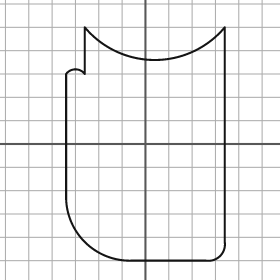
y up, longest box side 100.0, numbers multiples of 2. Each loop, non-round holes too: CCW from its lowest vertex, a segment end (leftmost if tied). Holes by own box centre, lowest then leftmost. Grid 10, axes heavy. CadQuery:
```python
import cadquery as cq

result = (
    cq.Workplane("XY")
    .moveTo(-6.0, -50.0)
    .lineTo(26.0, -50.0)
    .threePointArc((32.0, -48.0), (34.0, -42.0))
    .lineTo(34.0, 50.0)
    .threePointArc((4.0, 36.0), (-26.0, 50.0))
    .lineTo(-26.0, 30.0)
    .threePointArc((-30.0, 32.0), (-34.0, 30.0))
    .lineTo(-34.0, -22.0)
    .threePointArc((-26.0, -42.0), (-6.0, -50.0))
    .close()
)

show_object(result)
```